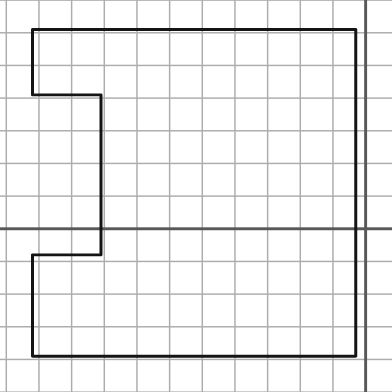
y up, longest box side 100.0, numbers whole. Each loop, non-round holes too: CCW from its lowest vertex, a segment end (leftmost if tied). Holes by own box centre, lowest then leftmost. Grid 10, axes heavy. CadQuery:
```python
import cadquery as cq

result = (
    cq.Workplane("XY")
    .moveTo(-102.0, -39.0)
    .lineTo(-3.0, -39.0)
    .lineTo(-3.0, 61.0)
    .lineTo(-102.0, 61.0)
    .lineTo(-102.0, 41.0)
    .lineTo(-81.0, 41.0)
    .lineTo(-81.0, -8.0)
    .lineTo(-102.0, -8.0)
    .close()
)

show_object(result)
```